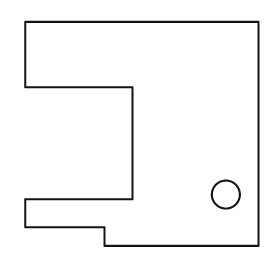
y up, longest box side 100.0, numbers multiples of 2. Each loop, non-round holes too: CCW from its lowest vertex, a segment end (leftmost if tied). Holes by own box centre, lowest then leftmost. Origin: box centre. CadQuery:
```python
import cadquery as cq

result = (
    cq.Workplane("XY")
    .moveTo(-16.0, -48.0)
    .lineTo(50.0, -48.0)
    .lineTo(50.0, 48.0)
    .lineTo(-50.0, 48.0)
    .lineTo(-50.0, 20.0)
    .lineTo(-4.0, 20.0)
    .lineTo(-4.0, -28.0)
    .lineTo(-50.0, -28.0)
    .lineTo(-50.0, -40.0)
    .lineTo(-16.0, -40.0)
    .close()
    .moveTo(36.0, -26.0)
    .circle(6.0)
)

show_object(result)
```